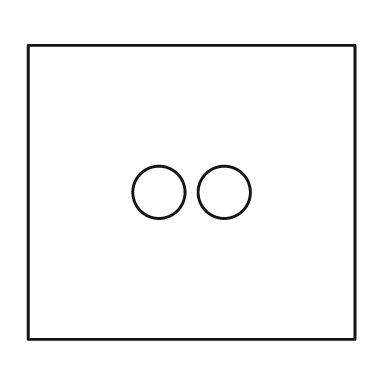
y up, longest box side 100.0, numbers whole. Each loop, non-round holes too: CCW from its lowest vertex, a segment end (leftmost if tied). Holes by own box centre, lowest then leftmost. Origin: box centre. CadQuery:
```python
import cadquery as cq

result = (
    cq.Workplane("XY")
    .moveTo(-50.0, -45.0)
    .lineTo(50.0, -45.0)
    .lineTo(50.0, 45.0)
    .lineTo(-50.0, 45.0)
    .close()
    .moveTo(-10.0, 0.0)
    .circle(8.0)
    .moveTo(10.0, 0.0)
    .circle(8.0)
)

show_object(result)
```